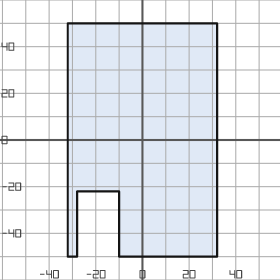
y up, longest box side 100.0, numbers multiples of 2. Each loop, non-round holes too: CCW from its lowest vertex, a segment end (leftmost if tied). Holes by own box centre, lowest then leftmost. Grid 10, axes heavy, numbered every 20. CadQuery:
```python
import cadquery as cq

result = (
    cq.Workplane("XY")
    .moveTo(-32.0, -50.0)
    .lineTo(-28.0, -50.0)
    .lineTo(-28.0, -22.0)
    .lineTo(-10.0, -22.0)
    .lineTo(-10.0, -50.0)
    .lineTo(32.0, -50.0)
    .lineTo(32.0, 50.0)
    .lineTo(-32.0, 50.0)
    .close()
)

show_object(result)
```